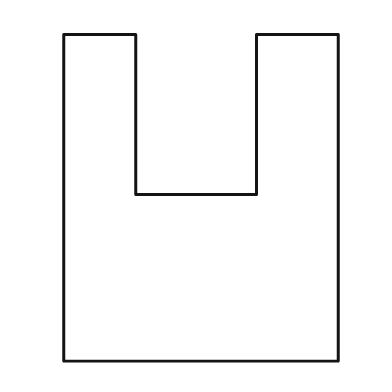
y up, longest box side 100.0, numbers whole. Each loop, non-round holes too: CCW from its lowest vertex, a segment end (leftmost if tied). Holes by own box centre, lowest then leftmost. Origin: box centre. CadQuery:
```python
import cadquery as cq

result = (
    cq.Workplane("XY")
    .moveTo(-42.0, -50.0)
    .lineTo(42.0, -50.0)
    .lineTo(42.0, 50.0)
    .lineTo(17.0, 50.0)
    .lineTo(17.0, 1.0)
    .lineTo(-20.0, 1.0)
    .lineTo(-20.0, 50.0)
    .lineTo(-42.0, 50.0)
    .close()
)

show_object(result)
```